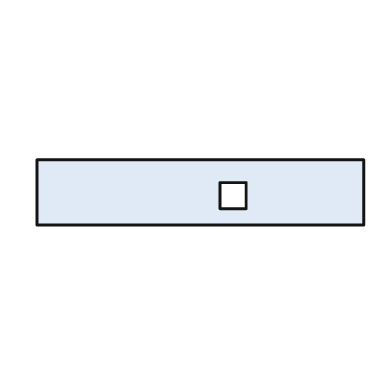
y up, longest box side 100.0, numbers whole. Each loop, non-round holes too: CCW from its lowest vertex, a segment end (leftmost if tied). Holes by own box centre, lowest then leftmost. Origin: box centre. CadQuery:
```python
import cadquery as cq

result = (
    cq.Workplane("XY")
    .moveTo(-50.0, -10.0)
    .lineTo(50.0, -10.0)
    .lineTo(50.0, 10.0)
    .lineTo(-50.0, 10.0)
    .close()
    .moveTo(6.0, -5.0)
    .lineTo(14.0, -5.0)
    .lineTo(14.0, 3.0)
    .lineTo(6.0, 3.0)
    .close()
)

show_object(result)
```